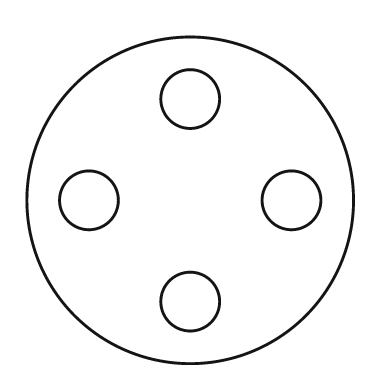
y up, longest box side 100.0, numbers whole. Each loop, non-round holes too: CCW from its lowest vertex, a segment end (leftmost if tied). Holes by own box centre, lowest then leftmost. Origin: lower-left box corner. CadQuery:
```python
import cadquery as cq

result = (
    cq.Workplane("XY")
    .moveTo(50.0, 50.0)
    .circle(50.0)
    .moveTo(50.0, 19.0)
    .circle(9.0)
    .moveTo(19.0, 50.0)
    .circle(9.0)
    .moveTo(81.0, 50.0)
    .circle(9.0)
    .moveTo(50.0, 81.0)
    .circle(9.0)
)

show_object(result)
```